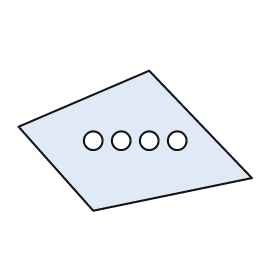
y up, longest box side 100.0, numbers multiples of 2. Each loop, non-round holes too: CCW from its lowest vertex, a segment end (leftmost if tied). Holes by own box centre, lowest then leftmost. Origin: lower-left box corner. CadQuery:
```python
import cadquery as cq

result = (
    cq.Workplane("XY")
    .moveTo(32.0, 0.0)
    .lineTo(100.0, 14.0)
    .lineTo(56.0, 60.0)
    .lineTo(0.0, 36.0)
    .close()
    .moveTo(32.0, 30.0)
    .circle(4.0)
    .moveTo(44.0, 30.0)
    .circle(4.0)
    .moveTo(56.0, 30.0)
    .circle(4.0)
    .moveTo(68.0, 30.0)
    .circle(4.0)
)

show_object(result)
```